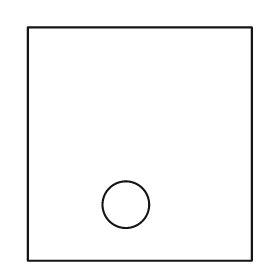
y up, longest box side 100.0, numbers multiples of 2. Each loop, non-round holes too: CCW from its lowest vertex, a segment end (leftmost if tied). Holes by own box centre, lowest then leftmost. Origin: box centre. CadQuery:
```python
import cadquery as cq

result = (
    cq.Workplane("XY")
    .moveTo(-48.0, -50.0)
    .lineTo(48.0, -50.0)
    .lineTo(48.0, 50.0)
    .lineTo(-48.0, 50.0)
    .close()
    .moveTo(-6.0, -26.0)
    .circle(10.0)
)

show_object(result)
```